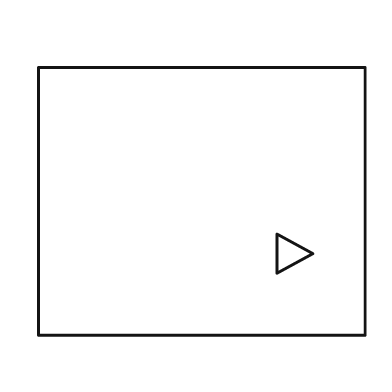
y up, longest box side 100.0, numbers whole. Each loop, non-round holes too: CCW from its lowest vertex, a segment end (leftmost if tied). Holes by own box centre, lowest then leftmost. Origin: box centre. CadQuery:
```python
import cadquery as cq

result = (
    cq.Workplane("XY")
    .moveTo(-50.0, -41.0)
    .lineTo(50.0, -41.0)
    .lineTo(50.0, 41.0)
    .lineTo(-50.0, 41.0)
    .close()
    .moveTo(23.0, -22.0)
    .lineTo(34.0, -16.0)
    .lineTo(23.0, -10.0)
    .close()
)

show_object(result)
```